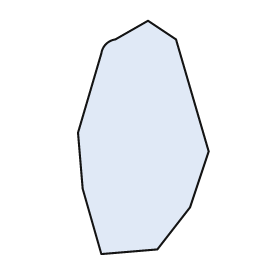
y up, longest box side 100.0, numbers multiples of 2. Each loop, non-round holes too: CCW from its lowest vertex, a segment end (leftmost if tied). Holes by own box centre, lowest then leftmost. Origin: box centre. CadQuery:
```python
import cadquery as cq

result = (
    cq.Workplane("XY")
    .moveTo(-18.0, -50.0)
    .lineTo(6.0, -48.0)
    .lineTo(20.0, -30.0)
    .lineTo(28.0, -6.0)
    .lineTo(14.0, 42.0)
    .lineTo(2.0, 50.0)
    .lineTo(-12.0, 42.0)
    .threePointArc((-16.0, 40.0), (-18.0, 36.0))
    .lineTo(-28.0, 2.0)
    .lineTo(-26.0, -22.0)
    .close()
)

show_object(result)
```